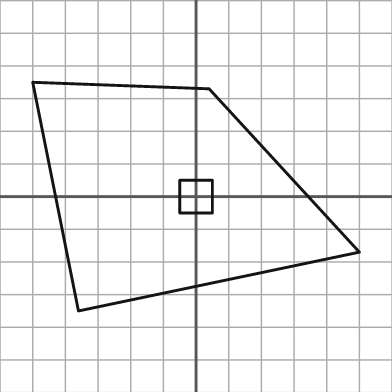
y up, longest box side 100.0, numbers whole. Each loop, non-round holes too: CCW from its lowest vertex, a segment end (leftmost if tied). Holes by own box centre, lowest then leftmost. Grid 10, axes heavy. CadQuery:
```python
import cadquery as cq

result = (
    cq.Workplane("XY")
    .moveTo(-36.0, -35.0)
    .lineTo(50.0, -17.0)
    .lineTo(4.0, 33.0)
    .lineTo(-50.0, 35.0)
    .close()
    .moveTo(-5.0, -5.0)
    .lineTo(5.0, -5.0)
    .lineTo(5.0, 5.0)
    .lineTo(-5.0, 5.0)
    .close()
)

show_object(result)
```